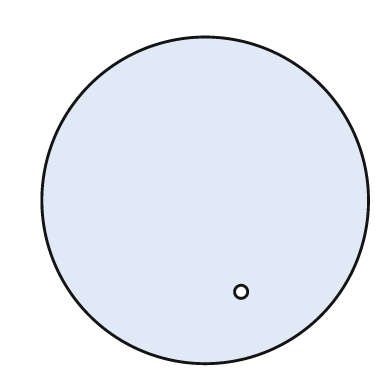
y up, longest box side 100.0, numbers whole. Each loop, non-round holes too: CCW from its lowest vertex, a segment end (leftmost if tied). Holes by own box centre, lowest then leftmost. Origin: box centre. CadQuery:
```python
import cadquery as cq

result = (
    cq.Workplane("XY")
    .moveTo(0.0, 0.0)
    .circle(50.0)
    .moveTo(11.0, -28.0)
    .circle(2.0)
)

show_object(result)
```